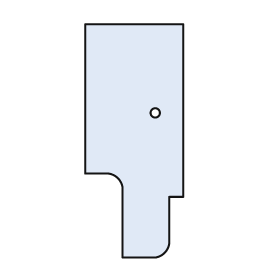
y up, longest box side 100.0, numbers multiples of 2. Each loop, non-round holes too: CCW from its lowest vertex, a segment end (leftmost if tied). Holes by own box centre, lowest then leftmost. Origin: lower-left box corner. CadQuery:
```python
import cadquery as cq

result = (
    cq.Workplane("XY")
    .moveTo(16.0, 0.0)
    .lineTo(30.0, 0.0)
    .threePointArc((34.0, 2.0), (36.0, 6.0))
    .lineTo(36.0, 26.0)
    .lineTo(42.0, 26.0)
    .lineTo(42.0, 100.0)
    .lineTo(0.0, 100.0)
    .lineTo(0.0, 36.0)
    .lineTo(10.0, 36.0)
    .threePointArc((14.0, 34.0), (16.0, 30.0))
    .close()
    .moveTo(30.0, 62.0)
    .circle(2.0)
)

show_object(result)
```